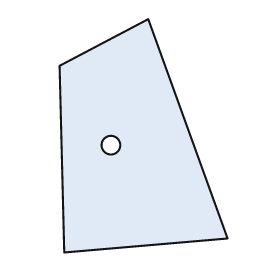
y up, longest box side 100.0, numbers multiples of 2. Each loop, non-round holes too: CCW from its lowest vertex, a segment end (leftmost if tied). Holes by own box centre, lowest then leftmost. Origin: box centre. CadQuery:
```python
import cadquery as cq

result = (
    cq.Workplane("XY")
    .moveTo(-34.0, -50.0)
    .lineTo(36.0, -44.0)
    .lineTo(2.0, 50.0)
    .lineTo(-36.0, 30.0)
    .close()
    .moveTo(-14.0, -4.0)
    .circle(4.0)
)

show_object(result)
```